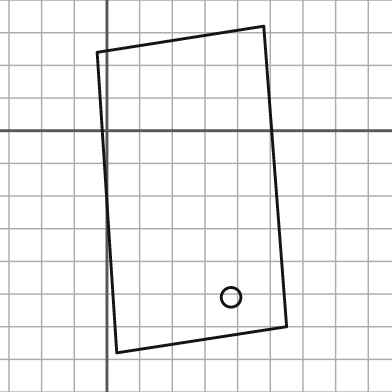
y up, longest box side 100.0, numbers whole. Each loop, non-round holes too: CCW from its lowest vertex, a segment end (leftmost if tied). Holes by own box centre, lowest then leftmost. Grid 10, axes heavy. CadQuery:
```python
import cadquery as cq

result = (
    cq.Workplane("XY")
    .moveTo(3.0, -68.0)
    .lineTo(55.0, -60.0)
    .lineTo(48.0, 32.0)
    .lineTo(-3.0, 24.0)
    .close()
    .moveTo(38.0, -51.0)
    .circle(3.0)
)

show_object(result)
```